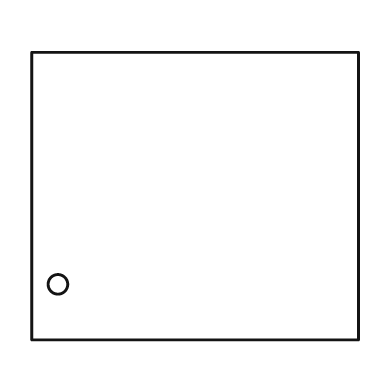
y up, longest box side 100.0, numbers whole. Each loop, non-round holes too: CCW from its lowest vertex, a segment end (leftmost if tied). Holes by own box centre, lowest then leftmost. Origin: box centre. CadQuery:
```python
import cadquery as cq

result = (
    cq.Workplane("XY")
    .moveTo(-50.0, -44.0)
    .lineTo(50.0, -44.0)
    .lineTo(50.0, 44.0)
    .lineTo(-50.0, 44.0)
    .close()
    .moveTo(-42.0, -27.0)
    .circle(3.0)
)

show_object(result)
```